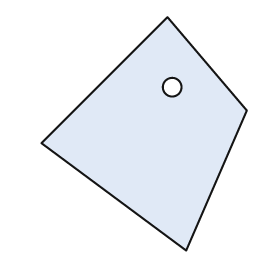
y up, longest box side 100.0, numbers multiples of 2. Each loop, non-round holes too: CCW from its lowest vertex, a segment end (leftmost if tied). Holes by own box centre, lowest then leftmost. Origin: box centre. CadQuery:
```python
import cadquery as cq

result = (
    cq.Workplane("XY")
    .moveTo(18.0, -50.0)
    .lineTo(44.0, 10.0)
    .lineTo(10.0, 50.0)
    .lineTo(-44.0, -4.0)
    .close()
    .moveTo(12.0, 20.0)
    .circle(4.0)
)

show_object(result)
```